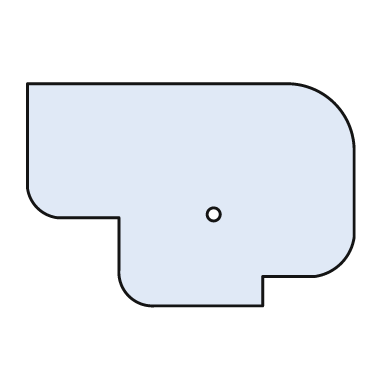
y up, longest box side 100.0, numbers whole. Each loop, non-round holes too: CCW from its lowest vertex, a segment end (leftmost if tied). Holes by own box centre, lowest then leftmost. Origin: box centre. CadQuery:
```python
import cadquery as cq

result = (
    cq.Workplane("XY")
    .moveTo(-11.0, -34.0)
    .lineTo(22.0, -34.0)
    .lineTo(22.0, -25.0)
    .lineTo(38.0, -25.0)
    .threePointArc((46.0, -21.0), (50.0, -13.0))
    .lineTo(50.0, 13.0)
    .threePointArc((44.0, 28.0), (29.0, 34.0))
    .lineTo(-50.0, 34.0)
    .lineTo(-50.0, 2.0)
    .threePointArc((-47.0, -4.0), (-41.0, -7.0))
    .lineTo(-22.0, -7.0)
    .lineTo(-22.0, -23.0)
    .threePointArc((-19.0, -31.0), (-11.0, -34.0))
    .close()
    .moveTo(7.0, -6.0)
    .circle(2.0)
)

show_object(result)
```